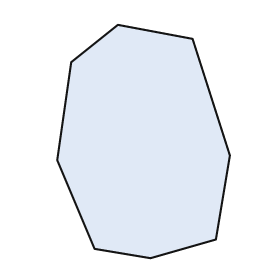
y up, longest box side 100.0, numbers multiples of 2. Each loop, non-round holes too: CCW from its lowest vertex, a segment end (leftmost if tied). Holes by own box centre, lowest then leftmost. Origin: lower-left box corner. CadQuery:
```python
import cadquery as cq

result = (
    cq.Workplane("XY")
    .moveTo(40.0, 0.0)
    .lineTo(68.0, 8.0)
    .lineTo(74.0, 44.0)
    .lineTo(58.0, 94.0)
    .lineTo(26.0, 100.0)
    .lineTo(6.0, 84.0)
    .lineTo(0.0, 42.0)
    .lineTo(16.0, 4.0)
    .close()
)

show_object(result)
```